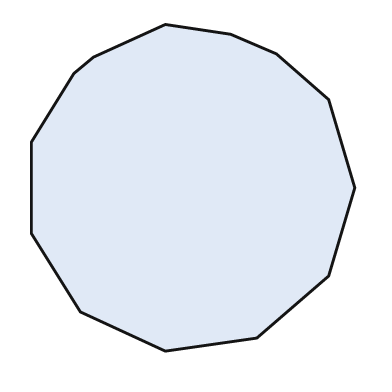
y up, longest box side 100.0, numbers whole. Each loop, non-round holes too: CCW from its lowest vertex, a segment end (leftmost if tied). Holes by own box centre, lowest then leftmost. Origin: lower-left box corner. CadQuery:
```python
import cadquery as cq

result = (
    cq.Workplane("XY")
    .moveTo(41.0, 0.0)
    .lineTo(69.0, 4.0)
    .lineTo(91.0, 23.0)
    .lineTo(99.0, 50.0)
    .lineTo(91.0, 77.0)
    .lineTo(75.0, 91.0)
    .lineTo(61.0, 97.0)
    .lineTo(41.0, 100.0)
    .lineTo(19.0, 90.0)
    .lineTo(13.0, 85.0)
    .lineTo(0.0, 64.0)
    .lineTo(0.0, 36.0)
    .lineTo(15.0, 12.0)
    .close()
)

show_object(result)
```